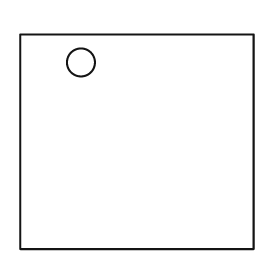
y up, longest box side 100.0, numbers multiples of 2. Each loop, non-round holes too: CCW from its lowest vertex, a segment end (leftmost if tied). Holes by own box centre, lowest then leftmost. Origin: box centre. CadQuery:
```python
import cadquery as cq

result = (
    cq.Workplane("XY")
    .moveTo(-50.0, -46.0)
    .lineTo(50.0, -46.0)
    .lineTo(50.0, 46.0)
    .lineTo(-50.0, 46.0)
    .close()
    .moveTo(-24.0, 34.0)
    .circle(6.0)
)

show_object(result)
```